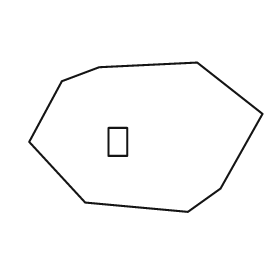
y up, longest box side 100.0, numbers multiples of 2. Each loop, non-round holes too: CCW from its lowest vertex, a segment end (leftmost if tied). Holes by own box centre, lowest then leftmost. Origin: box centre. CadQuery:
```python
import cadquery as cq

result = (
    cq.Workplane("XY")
    .moveTo(18.0, -32.0)
    .lineTo(32.0, -22.0)
    .lineTo(50.0, 10.0)
    .lineTo(22.0, 32.0)
    .lineTo(-20.0, 30.0)
    .lineTo(-36.0, 24.0)
    .lineTo(-50.0, -2.0)
    .lineTo(-26.0, -28.0)
    .close()
    .moveTo(-16.0, -8.0)
    .lineTo(-8.0, -8.0)
    .lineTo(-8.0, 4.0)
    .lineTo(-16.0, 4.0)
    .close()
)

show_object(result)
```